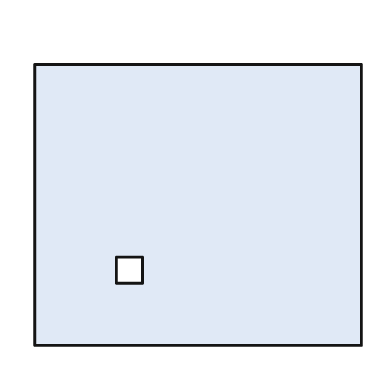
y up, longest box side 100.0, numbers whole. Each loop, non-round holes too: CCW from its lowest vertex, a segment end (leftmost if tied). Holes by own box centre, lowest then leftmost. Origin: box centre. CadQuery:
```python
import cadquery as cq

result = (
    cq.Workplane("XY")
    .moveTo(-50.0, -43.0)
    .lineTo(50.0, -43.0)
    .lineTo(50.0, 43.0)
    .lineTo(-50.0, 43.0)
    .close()
    .moveTo(-25.0, -24.0)
    .lineTo(-17.0, -24.0)
    .lineTo(-17.0, -16.0)
    .lineTo(-25.0, -16.0)
    .close()
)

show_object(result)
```